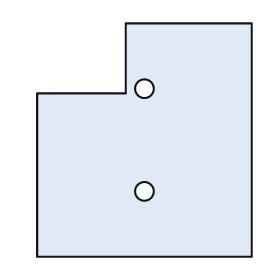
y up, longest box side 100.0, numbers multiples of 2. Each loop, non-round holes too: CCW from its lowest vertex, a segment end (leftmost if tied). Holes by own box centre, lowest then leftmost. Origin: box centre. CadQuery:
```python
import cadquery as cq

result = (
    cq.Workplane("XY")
    .moveTo(-46.0, -50.0)
    .lineTo(46.0, -50.0)
    .lineTo(46.0, 50.0)
    .lineTo(-8.0, 50.0)
    .lineTo(-8.0, 20.0)
    .lineTo(-46.0, 20.0)
    .close()
    .moveTo(0.0, -22.0)
    .circle(4.0)
    .moveTo(0.0, 22.0)
    .circle(4.0)
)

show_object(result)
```